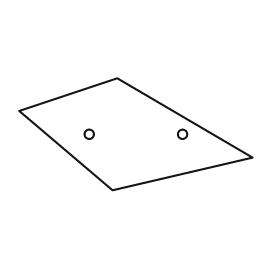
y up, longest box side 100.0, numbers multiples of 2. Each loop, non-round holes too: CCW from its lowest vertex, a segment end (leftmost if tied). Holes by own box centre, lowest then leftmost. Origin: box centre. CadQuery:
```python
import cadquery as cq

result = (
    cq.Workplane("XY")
    .moveTo(-10.0, -24.0)
    .lineTo(50.0, -10.0)
    .lineTo(-8.0, 24.0)
    .lineTo(-50.0, 10.0)
    .close()
    .moveTo(-20.0, 0.0)
    .circle(2.0)
    .moveTo(20.0, 0.0)
    .circle(2.0)
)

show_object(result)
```